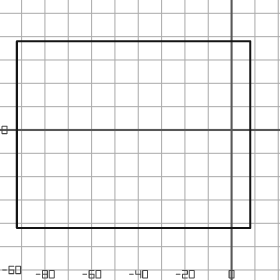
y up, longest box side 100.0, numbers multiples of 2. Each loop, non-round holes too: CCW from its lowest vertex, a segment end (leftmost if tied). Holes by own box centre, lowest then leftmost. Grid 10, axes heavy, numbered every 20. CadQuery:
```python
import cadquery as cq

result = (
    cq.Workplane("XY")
    .moveTo(-92.0, -42.0)
    .lineTo(8.0, -42.0)
    .lineTo(8.0, 38.0)
    .lineTo(-92.0, 38.0)
    .close()
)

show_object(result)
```